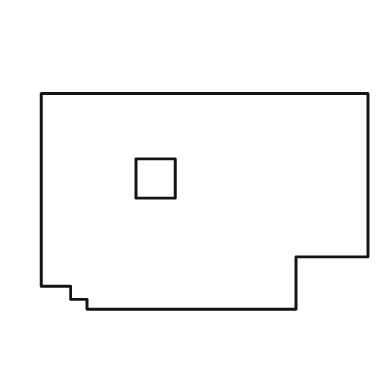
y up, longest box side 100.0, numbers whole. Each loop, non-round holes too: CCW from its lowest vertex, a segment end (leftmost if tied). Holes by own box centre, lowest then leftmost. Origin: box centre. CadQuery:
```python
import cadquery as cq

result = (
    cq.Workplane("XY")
    .moveTo(-36.0, -33.0)
    .lineTo(28.0, -33.0)
    .lineTo(28.0, -17.0)
    .lineTo(50.0, -17.0)
    .lineTo(50.0, 33.0)
    .lineTo(-50.0, 33.0)
    .lineTo(-50.0, -26.0)
    .lineTo(-41.0, -26.0)
    .lineTo(-41.0, -30.0)
    .lineTo(-36.0, -30.0)
    .close()
    .moveTo(-21.0, 1.0)
    .lineTo(-9.0, 1.0)
    .lineTo(-9.0, 13.0)
    .lineTo(-21.0, 13.0)
    .close()
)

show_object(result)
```